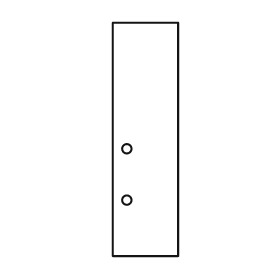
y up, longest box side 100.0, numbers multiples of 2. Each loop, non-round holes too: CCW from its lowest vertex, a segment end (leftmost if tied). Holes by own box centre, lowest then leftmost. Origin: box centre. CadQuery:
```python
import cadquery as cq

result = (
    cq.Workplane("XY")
    .moveTo(-14.0, -50.0)
    .lineTo(14.0, -50.0)
    .lineTo(14.0, 50.0)
    .lineTo(-14.0, 50.0)
    .close()
    .moveTo(-8.0, -26.0)
    .circle(2.0)
    .moveTo(-8.0, -4.0)
    .circle(2.0)
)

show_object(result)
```